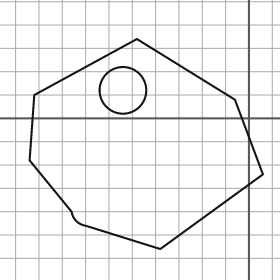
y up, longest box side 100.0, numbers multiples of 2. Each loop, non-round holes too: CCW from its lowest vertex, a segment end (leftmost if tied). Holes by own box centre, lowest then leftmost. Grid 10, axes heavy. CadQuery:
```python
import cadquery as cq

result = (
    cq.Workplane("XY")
    .moveTo(-38.0, -56.0)
    .lineTo(6.0, -24.0)
    .lineTo(-6.0, 8.0)
    .lineTo(-48.0, 34.0)
    .lineTo(-92.0, 10.0)
    .lineTo(-94.0, -18.0)
    .lineTo(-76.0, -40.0)
    .threePointArc((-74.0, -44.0), (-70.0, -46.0))
    .close()
    .moveTo(-54.0, 12.0)
    .circle(10.0)
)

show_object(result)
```